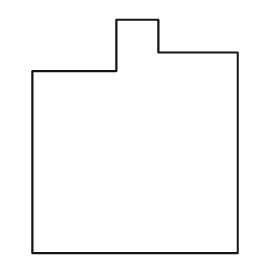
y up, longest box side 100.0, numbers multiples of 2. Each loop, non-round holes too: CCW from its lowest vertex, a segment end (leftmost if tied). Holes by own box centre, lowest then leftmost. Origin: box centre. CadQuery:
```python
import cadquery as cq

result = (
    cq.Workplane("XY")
    .moveTo(-44.0, -50.0)
    .lineTo(44.0, -50.0)
    .lineTo(44.0, 36.0)
    .lineTo(10.0, 36.0)
    .lineTo(10.0, 50.0)
    .lineTo(-8.0, 50.0)
    .lineTo(-8.0, 28.0)
    .lineTo(-44.0, 28.0)
    .close()
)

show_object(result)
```